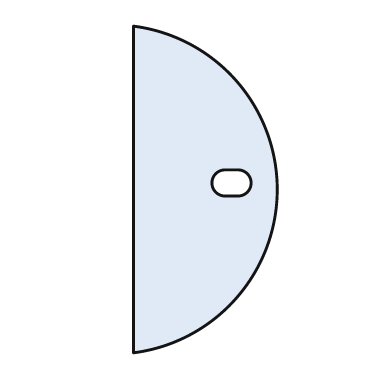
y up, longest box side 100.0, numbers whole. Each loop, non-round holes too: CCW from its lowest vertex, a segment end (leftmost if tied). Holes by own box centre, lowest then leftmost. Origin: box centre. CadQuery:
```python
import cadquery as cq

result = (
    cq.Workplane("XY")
    .moveTo(-22.0, -50.0)
    .threePointArc((22.0, 0.0), (-22.0, 50.0))
    .close()
    .moveTo(6.0, -2.0)
    .lineTo(10.0, -2.0)
    .threePointArc((14.0, 2.0), (10.0, 6.0))
    .lineTo(6.0, 6.0)
    .threePointArc((2.0, 2.0), (6.0, -2.0))
    .close()
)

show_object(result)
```